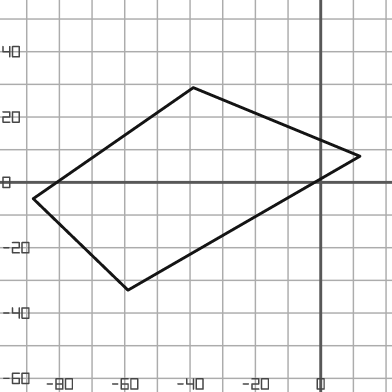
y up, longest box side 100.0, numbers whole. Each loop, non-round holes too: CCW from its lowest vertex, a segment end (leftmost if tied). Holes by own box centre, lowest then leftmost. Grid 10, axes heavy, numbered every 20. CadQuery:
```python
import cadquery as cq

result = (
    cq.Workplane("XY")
    .moveTo(-59.0, -33.0)
    .lineTo(12.0, 8.0)
    .lineTo(-39.0, 29.0)
    .lineTo(-88.0, -5.0)
    .close()
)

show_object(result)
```